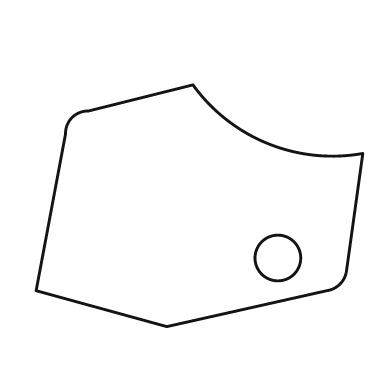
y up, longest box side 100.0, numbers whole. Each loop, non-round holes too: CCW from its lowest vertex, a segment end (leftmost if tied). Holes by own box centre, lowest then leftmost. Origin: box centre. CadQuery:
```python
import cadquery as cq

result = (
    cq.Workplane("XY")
    .moveTo(-10.0, -37.0)
    .lineTo(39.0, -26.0)
    .threePointArc((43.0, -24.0), (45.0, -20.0))
    .lineTo(50.0, 16.0)
    .threePointArc((21.0, 19.0), (-2.0, 37.0))
    .lineTo(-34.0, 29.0)
    .threePointArc((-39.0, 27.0), (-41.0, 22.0))
    .lineTo(-50.0, -26.0)
    .close()
    .moveTo(24.0, -16.0)
    .circle(7.0)
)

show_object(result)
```